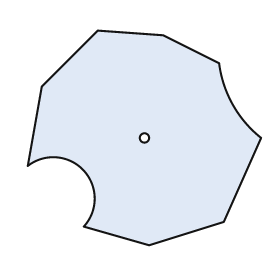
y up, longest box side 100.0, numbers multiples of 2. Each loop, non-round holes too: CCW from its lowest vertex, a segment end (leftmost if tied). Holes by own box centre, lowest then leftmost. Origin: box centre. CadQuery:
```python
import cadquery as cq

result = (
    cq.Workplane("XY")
    .moveTo(2.0, -46.0)
    .lineTo(34.0, -36.0)
    .lineTo(50.0, 0.0)
    .threePointArc((38.0, 14.0), (32.0, 32.0))
    .lineTo(8.0, 44.0)
    .lineTo(-20.0, 46.0)
    .lineTo(-44.0, 22.0)
    .lineTo(-50.0, -12.0)
    .threePointArc((-26.0, -14.0), (-26.0, -38.0))
    .close()
    .moveTo(0.0, 0.0)
    .circle(2.0)
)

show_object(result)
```